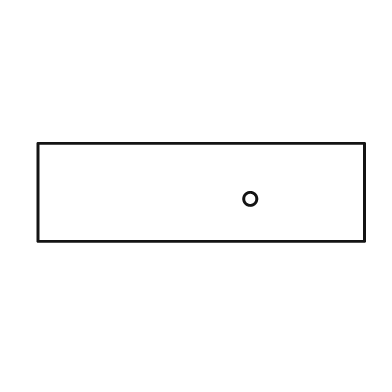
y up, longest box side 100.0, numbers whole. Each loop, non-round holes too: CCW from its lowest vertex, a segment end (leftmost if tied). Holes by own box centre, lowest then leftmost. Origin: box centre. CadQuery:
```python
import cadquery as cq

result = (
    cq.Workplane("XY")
    .moveTo(-50.0, -15.0)
    .lineTo(50.0, -15.0)
    .lineTo(50.0, 15.0)
    .lineTo(-50.0, 15.0)
    .close()
    .moveTo(15.0, -2.0)
    .circle(2.0)
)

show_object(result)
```